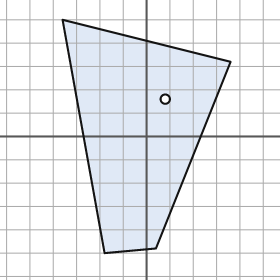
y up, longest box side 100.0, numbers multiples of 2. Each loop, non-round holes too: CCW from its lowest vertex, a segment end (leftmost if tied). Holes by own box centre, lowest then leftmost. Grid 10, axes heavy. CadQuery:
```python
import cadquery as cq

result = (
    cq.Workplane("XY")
    .moveTo(-18.0, -50.0)
    .lineTo(4.0, -48.0)
    .lineTo(36.0, 32.0)
    .lineTo(-36.0, 50.0)
    .close()
    .moveTo(8.0, 16.0)
    .circle(2.0)
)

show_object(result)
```